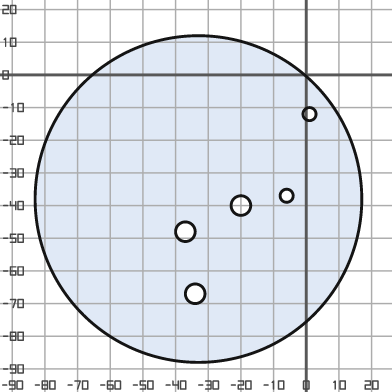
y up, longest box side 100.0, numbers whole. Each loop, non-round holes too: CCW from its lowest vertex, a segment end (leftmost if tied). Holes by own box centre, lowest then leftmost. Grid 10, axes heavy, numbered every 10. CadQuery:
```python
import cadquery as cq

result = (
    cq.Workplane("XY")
    .moveTo(-33.0, -38.0)
    .circle(50.0)
    .moveTo(-34.0, -67.0)
    .circle(3.0)
    .moveTo(-37.0, -48.0)
    .circle(3.0)
    .moveTo(-20.0, -40.0)
    .circle(3.0)
    .moveTo(-6.0, -37.0)
    .circle(2.0)
    .moveTo(1.0, -12.0)
    .circle(2.0)
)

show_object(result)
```